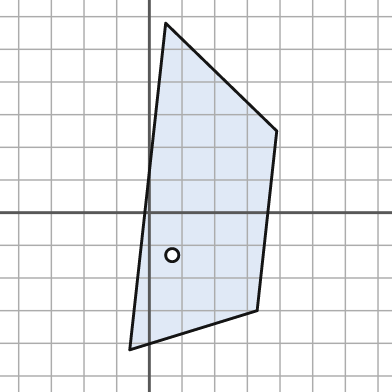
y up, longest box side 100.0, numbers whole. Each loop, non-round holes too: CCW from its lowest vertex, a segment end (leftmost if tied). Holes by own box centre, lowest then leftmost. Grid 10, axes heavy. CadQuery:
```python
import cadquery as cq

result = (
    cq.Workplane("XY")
    .moveTo(-6.0, -42.0)
    .lineTo(33.0, -30.0)
    .lineTo(39.0, 25.0)
    .lineTo(5.0, 58.0)
    .close()
    .moveTo(7.0, -13.0)
    .circle(2.0)
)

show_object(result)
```